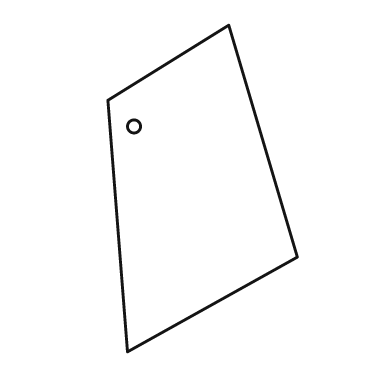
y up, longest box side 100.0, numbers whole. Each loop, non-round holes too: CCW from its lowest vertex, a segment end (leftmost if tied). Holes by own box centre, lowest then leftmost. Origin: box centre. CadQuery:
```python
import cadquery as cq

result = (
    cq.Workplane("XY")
    .moveTo(-23.0, -50.0)
    .lineTo(29.0, -21.0)
    .lineTo(8.0, 50.0)
    .lineTo(-29.0, 27.0)
    .close()
    .moveTo(-21.0, 19.0)
    .circle(2.0)
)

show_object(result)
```